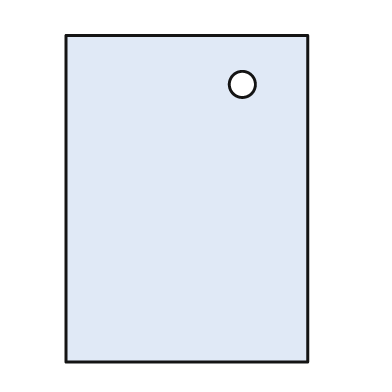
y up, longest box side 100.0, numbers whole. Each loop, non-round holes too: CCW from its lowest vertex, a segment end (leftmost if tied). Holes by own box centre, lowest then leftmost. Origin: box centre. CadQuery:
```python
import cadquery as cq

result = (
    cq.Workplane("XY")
    .moveTo(-37.0, -50.0)
    .lineTo(37.0, -50.0)
    .lineTo(37.0, 50.0)
    .lineTo(-37.0, 50.0)
    .close()
    .moveTo(17.0, 35.0)
    .circle(4.0)
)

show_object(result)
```